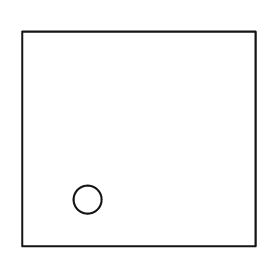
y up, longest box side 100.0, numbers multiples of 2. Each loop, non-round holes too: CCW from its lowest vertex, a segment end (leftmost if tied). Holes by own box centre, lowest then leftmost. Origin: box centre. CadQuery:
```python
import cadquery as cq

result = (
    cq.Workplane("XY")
    .moveTo(-50.0, -46.0)
    .lineTo(50.0, -46.0)
    .lineTo(50.0, 46.0)
    .lineTo(-50.0, 46.0)
    .close()
    .moveTo(-22.0, -26.0)
    .circle(6.0)
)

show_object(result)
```